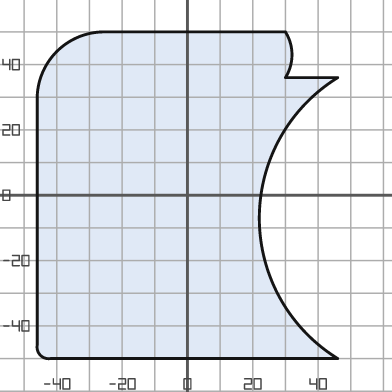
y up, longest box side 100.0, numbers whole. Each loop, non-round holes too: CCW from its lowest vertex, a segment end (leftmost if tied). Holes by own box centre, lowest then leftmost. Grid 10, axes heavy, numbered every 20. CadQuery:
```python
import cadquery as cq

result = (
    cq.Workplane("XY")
    .moveTo(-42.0, -50.0)
    .lineTo(46.0, -50.0)
    .threePointArc((22.0, -7.0), (46.0, 36.0))
    .lineTo(30.0, 36.0)
    .threePointArc((32.0, 43.0), (30.0, 50.0))
    .lineTo(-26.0, 50.0)
    .threePointArc((-40.0, 44.0), (-46.0, 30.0))
    .lineTo(-46.0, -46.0)
    .threePointArc((-45.0, -49.0), (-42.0, -50.0))
    .close()
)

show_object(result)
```